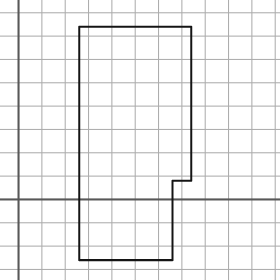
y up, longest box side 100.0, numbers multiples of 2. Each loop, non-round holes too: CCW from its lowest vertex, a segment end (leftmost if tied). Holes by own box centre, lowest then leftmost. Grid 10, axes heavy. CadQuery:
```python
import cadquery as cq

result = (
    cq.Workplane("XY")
    .moveTo(26.0, -26.0)
    .lineTo(66.0, -26.0)
    .lineTo(66.0, 8.0)
    .lineTo(74.0, 8.0)
    .lineTo(74.0, 74.0)
    .lineTo(26.0, 74.0)
    .close()
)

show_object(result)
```